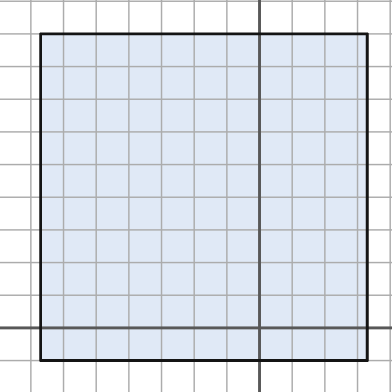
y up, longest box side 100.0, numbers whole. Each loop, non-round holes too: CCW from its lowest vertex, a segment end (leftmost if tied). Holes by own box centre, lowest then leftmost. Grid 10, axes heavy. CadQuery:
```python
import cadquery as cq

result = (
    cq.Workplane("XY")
    .moveTo(-67.0, -10.0)
    .lineTo(33.0, -10.0)
    .lineTo(33.0, 90.0)
    .lineTo(-67.0, 90.0)
    .close()
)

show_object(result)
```